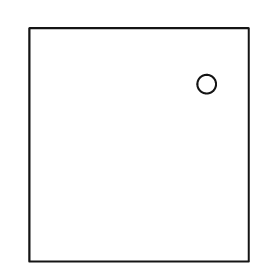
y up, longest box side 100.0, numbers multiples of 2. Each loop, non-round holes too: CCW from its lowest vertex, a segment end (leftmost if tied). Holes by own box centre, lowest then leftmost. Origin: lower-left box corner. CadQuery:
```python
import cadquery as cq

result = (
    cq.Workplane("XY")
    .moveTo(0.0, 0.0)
    .lineTo(94.0, 0.0)
    .lineTo(94.0, 100.0)
    .lineTo(0.0, 100.0)
    .close()
    .moveTo(76.0, 76.0)
    .circle(4.0)
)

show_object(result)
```